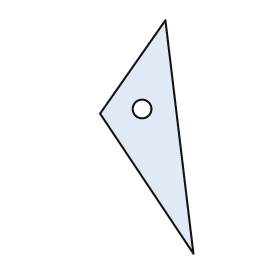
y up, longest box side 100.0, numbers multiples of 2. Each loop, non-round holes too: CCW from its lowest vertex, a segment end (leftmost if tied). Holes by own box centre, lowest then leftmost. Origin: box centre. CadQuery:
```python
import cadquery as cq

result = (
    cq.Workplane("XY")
    .moveTo(20.0, -50.0)
    .lineTo(8.0, 50.0)
    .lineTo(-20.0, 10.0)
    .close()
    .moveTo(-2.0, 12.0)
    .circle(4.0)
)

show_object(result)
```